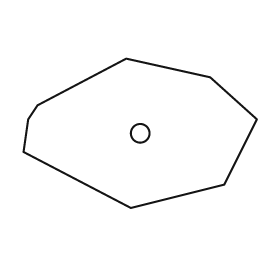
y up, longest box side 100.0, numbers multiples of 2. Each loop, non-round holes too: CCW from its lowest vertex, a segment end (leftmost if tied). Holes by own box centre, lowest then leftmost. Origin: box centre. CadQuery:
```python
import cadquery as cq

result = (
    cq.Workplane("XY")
    .moveTo(-4.0, -32.0)
    .lineTo(36.0, -22.0)
    .lineTo(50.0, 6.0)
    .lineTo(30.0, 24.0)
    .lineTo(-6.0, 32.0)
    .lineTo(-44.0, 12.0)
    .lineTo(-48.0, 6.0)
    .lineTo(-50.0, -8.0)
    .close()
    .moveTo(0.0, 0.0)
    .circle(4.0)
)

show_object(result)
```